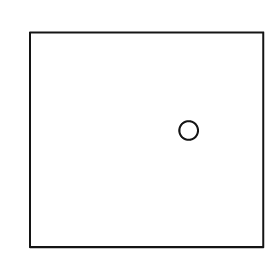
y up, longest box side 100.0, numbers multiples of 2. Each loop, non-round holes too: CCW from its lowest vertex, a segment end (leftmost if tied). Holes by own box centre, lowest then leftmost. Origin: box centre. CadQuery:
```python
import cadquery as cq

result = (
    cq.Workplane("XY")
    .moveTo(-50.0, -46.0)
    .lineTo(50.0, -46.0)
    .lineTo(50.0, 46.0)
    .lineTo(-50.0, 46.0)
    .close()
    .moveTo(18.0, 4.0)
    .circle(4.0)
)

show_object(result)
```